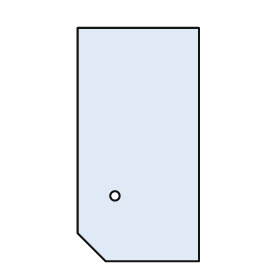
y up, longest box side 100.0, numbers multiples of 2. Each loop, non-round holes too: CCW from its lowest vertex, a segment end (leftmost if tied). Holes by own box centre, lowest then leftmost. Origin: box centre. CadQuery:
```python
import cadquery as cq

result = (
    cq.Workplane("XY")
    .moveTo(-14.0, -50.0)
    .lineTo(26.0, -50.0)
    .lineTo(26.0, 50.0)
    .lineTo(-26.0, 50.0)
    .lineTo(-26.0, -38.0)
    .close()
    .moveTo(-10.0, -22.0)
    .circle(2.0)
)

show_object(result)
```